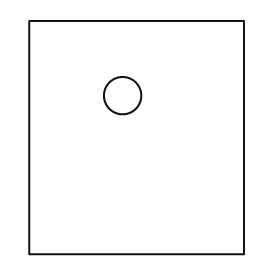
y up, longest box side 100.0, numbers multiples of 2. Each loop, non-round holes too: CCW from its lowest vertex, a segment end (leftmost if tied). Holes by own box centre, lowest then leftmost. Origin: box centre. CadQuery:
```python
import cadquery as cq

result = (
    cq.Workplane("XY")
    .moveTo(-46.0, -50.0)
    .lineTo(46.0, -50.0)
    .lineTo(46.0, 50.0)
    .lineTo(-46.0, 50.0)
    .close()
    .moveTo(-6.0, 18.0)
    .circle(8.0)
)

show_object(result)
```